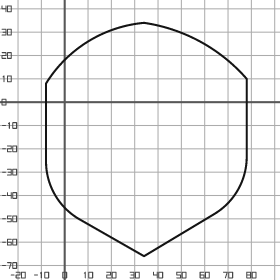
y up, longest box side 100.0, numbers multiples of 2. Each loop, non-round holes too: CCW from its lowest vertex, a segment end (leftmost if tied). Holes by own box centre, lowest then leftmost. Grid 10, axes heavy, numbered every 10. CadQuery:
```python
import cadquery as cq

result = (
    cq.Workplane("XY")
    .moveTo(34.0, -66.0)
    .lineTo(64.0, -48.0)
    .threePointArc((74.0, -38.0), (78.0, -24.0))
    .lineTo(78.0, 10.0)
    .threePointArc((58.0, 26.0), (34.0, 34.0))
    .threePointArc((10.0, 26.0), (-8.0, 8.0))
    .lineTo(-8.0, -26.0)
    .threePointArc((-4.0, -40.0), (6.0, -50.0))
    .close()
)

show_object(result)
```